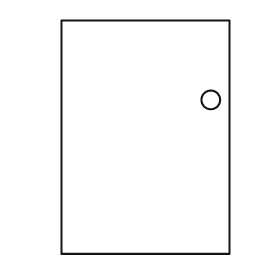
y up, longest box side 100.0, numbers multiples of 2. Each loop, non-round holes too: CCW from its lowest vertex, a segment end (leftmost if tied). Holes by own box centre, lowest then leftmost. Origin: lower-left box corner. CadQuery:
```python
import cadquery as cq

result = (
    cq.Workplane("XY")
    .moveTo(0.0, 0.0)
    .lineTo(72.0, 0.0)
    .lineTo(72.0, 100.0)
    .lineTo(0.0, 100.0)
    .close()
    .moveTo(64.0, 66.0)
    .circle(4.0)
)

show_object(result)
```